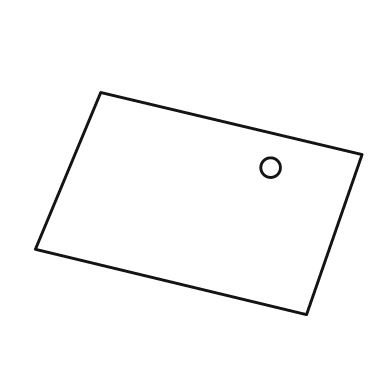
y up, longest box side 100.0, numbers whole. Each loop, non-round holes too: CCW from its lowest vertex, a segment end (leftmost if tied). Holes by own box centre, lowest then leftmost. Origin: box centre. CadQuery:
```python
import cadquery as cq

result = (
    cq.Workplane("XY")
    .moveTo(33.0, -34.0)
    .lineTo(50.0, 15.0)
    .lineTo(-30.0, 34.0)
    .lineTo(-50.0, -14.0)
    .close()
    .moveTo(22.0, 11.0)
    .circle(3.0)
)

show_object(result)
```